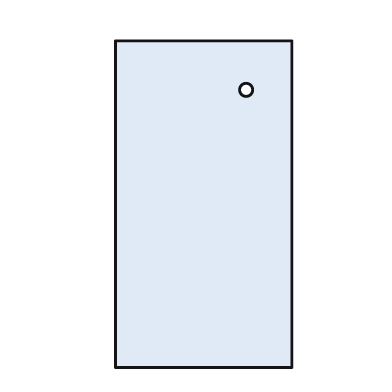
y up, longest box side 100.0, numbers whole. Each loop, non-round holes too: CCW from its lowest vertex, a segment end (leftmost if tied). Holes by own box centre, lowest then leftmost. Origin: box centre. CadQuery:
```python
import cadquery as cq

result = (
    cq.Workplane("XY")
    .moveTo(-27.0, -50.0)
    .lineTo(27.0, -50.0)
    .lineTo(27.0, 50.0)
    .lineTo(-27.0, 50.0)
    .close()
    .moveTo(13.0, 35.0)
    .circle(2.0)
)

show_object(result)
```